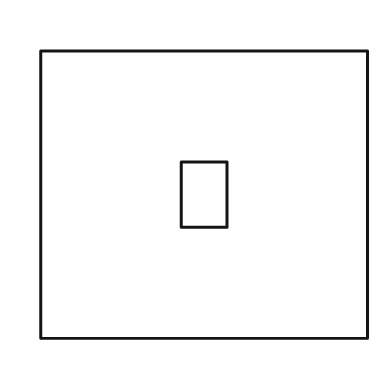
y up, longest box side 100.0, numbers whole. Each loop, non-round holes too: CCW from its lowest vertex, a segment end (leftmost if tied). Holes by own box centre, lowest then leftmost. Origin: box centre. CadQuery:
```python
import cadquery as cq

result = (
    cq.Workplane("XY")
    .moveTo(-50.0, -44.0)
    .lineTo(50.0, -44.0)
    .lineTo(50.0, 44.0)
    .lineTo(-50.0, 44.0)
    .close()
    .moveTo(-7.0, -10.0)
    .lineTo(7.0, -10.0)
    .lineTo(7.0, 10.0)
    .lineTo(-7.0, 10.0)
    .close()
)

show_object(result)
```